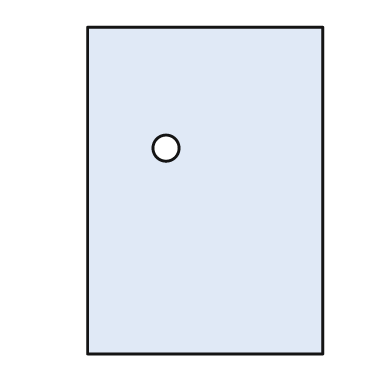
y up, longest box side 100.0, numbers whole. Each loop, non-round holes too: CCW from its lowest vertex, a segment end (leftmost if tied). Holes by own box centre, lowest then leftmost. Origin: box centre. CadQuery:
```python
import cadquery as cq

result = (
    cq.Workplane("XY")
    .moveTo(-36.0, -50.0)
    .lineTo(36.0, -50.0)
    .lineTo(36.0, 50.0)
    .lineTo(-36.0, 50.0)
    .close()
    .moveTo(-12.0, 13.0)
    .circle(4.0)
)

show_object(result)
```